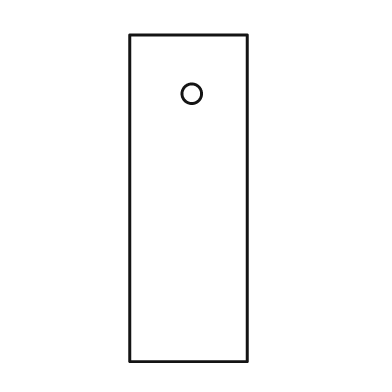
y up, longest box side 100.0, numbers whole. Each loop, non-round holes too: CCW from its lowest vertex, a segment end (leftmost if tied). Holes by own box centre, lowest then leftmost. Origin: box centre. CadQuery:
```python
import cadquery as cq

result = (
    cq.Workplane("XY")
    .moveTo(-18.0, -50.0)
    .lineTo(18.0, -50.0)
    .lineTo(18.0, 50.0)
    .lineTo(-18.0, 50.0)
    .close()
    .moveTo(1.0, 32.0)
    .circle(3.0)
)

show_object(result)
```